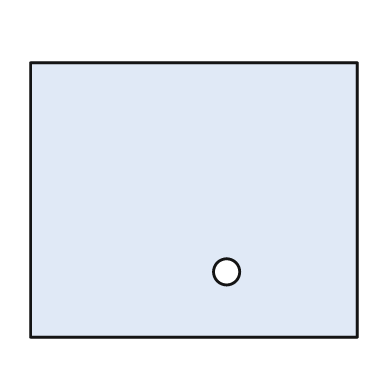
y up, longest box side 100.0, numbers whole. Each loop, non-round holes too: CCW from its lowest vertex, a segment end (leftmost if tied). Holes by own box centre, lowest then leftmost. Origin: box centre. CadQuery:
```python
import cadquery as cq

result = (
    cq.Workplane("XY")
    .moveTo(-50.0, -42.0)
    .lineTo(50.0, -42.0)
    .lineTo(50.0, 42.0)
    .lineTo(-50.0, 42.0)
    .close()
    .moveTo(10.0, -22.0)
    .circle(4.0)
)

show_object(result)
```